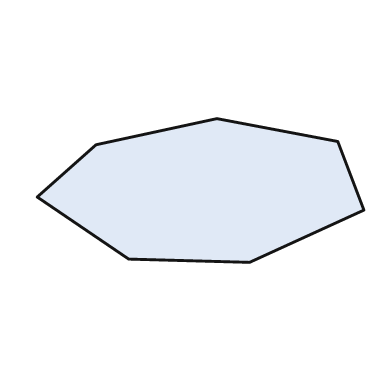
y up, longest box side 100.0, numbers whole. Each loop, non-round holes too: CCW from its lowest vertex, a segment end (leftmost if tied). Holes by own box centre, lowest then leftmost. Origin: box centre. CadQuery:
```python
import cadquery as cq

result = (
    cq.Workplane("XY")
    .moveTo(15.0, -22.0)
    .lineTo(50.0, -6.0)
    .lineTo(42.0, 15.0)
    .lineTo(5.0, 22.0)
    .lineTo(-32.0, 14.0)
    .lineTo(-50.0, -2.0)
    .lineTo(-22.0, -21.0)
    .close()
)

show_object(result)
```